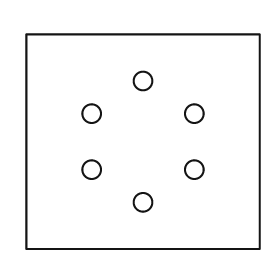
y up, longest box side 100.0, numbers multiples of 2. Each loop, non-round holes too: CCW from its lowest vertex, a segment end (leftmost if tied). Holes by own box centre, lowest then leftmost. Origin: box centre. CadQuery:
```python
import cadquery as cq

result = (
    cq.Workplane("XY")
    .moveTo(-50.0, -46.0)
    .lineTo(50.0, -46.0)
    .lineTo(50.0, 46.0)
    .lineTo(-50.0, 46.0)
    .close()
    .moveTo(0.0, -26.0)
    .circle(4.0)
    .moveTo(-22.0, -12.0)
    .circle(4.0)
    .moveTo(22.0, -12.0)
    .circle(4.0)
    .moveTo(-22.0, 12.0)
    .circle(4.0)
    .moveTo(22.0, 12.0)
    .circle(4.0)
    .moveTo(0.0, 26.0)
    .circle(4.0)
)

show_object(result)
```